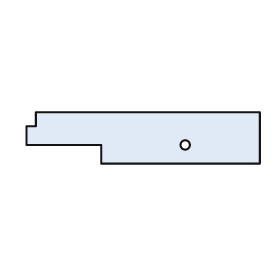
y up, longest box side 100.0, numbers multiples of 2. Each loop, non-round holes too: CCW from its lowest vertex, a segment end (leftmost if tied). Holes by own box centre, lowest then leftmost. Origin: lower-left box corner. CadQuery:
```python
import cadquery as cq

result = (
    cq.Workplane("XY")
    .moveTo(32.0, 0.0)
    .lineTo(100.0, 0.0)
    .lineTo(100.0, 22.0)
    .lineTo(4.0, 22.0)
    .lineTo(4.0, 16.0)
    .lineTo(0.0, 16.0)
    .lineTo(0.0, 8.0)
    .lineTo(32.0, 8.0)
    .close()
    .moveTo(68.0, 8.0)
    .circle(2.0)
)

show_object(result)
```